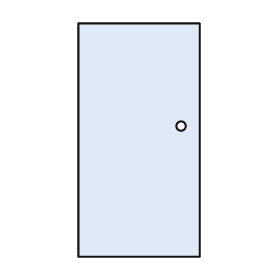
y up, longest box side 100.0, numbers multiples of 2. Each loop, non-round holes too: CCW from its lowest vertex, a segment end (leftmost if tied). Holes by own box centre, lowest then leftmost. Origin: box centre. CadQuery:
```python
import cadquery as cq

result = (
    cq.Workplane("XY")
    .moveTo(-26.0, -50.0)
    .lineTo(26.0, -50.0)
    .lineTo(26.0, 50.0)
    .lineTo(-26.0, 50.0)
    .close()
    .moveTo(18.0, 6.0)
    .circle(2.0)
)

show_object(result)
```